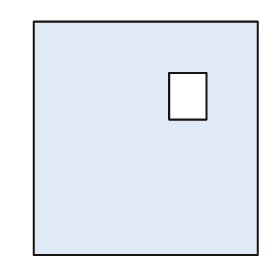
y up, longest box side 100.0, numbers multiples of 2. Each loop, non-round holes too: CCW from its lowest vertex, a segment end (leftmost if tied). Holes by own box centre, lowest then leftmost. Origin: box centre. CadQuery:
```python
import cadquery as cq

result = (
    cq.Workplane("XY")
    .moveTo(-48.0, -50.0)
    .lineTo(48.0, -50.0)
    .lineTo(48.0, 50.0)
    .lineTo(-48.0, 50.0)
    .close()
    .moveTo(10.0, 8.0)
    .lineTo(26.0, 8.0)
    .lineTo(26.0, 28.0)
    .lineTo(10.0, 28.0)
    .close()
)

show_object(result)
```